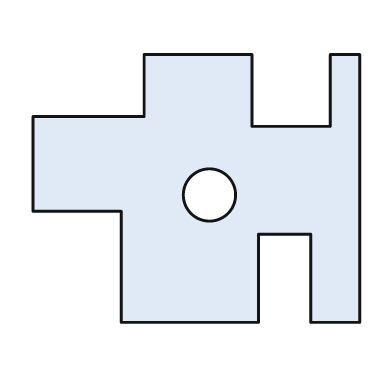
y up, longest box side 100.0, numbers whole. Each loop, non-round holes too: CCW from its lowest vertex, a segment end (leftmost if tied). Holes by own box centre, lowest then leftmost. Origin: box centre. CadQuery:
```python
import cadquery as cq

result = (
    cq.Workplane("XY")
    .moveTo(-23.0, -41.0)
    .lineTo(19.0, -41.0)
    .lineTo(19.0, -14.0)
    .lineTo(35.0, -14.0)
    .lineTo(35.0, -41.0)
    .lineTo(50.0, -41.0)
    .lineTo(50.0, 41.0)
    .lineTo(41.0, 41.0)
    .lineTo(41.0, 19.0)
    .lineTo(17.0, 19.0)
    .lineTo(17.0, 41.0)
    .lineTo(-16.0, 41.0)
    .lineTo(-16.0, 22.0)
    .lineTo(-50.0, 22.0)
    .lineTo(-50.0, -7.0)
    .lineTo(-23.0, -7.0)
    .close()
    .moveTo(4.0, -2.0)
    .circle(8.0)
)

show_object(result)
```